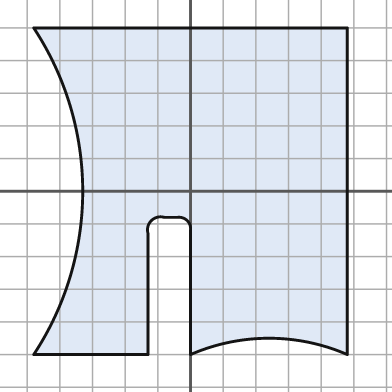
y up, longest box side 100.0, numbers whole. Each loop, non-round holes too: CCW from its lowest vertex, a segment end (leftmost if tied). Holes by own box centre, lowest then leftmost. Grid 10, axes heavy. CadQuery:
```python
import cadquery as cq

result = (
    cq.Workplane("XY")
    .moveTo(-48.0, -50.0)
    .lineTo(-13.0, -50.0)
    .lineTo(-13.0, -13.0)
    .threePointArc((-12.0, -9.0), (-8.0, -8.0))
    .lineTo(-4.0, -8.0)
    .threePointArc((-1.0, -9.0), (0.0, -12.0))
    .lineTo(0.0, -50.0)
    .threePointArc((24.0, -45.0), (48.0, -50.0))
    .lineTo(48.0, 50.0)
    .lineTo(-48.0, 50.0)
    .threePointArc((-33.0, 0.0), (-48.0, -50.0))
    .close()
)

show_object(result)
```